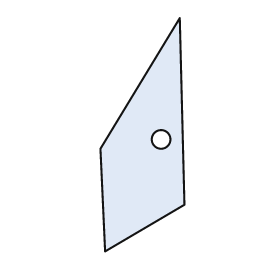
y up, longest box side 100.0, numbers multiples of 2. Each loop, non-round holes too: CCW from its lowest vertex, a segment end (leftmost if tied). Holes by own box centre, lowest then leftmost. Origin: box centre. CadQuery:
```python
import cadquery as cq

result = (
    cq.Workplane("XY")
    .moveTo(-16.0, -50.0)
    .lineTo(18.0, -30.0)
    .lineTo(16.0, 50.0)
    .lineTo(-18.0, -6.0)
    .close()
    .moveTo(8.0, -2.0)
    .circle(4.0)
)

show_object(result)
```